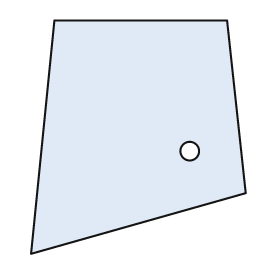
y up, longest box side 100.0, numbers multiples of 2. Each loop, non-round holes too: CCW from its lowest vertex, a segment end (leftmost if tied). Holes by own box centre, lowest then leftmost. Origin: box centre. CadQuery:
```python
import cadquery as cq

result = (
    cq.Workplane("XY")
    .moveTo(-46.0, -50.0)
    .lineTo(46.0, -24.0)
    .lineTo(38.0, 50.0)
    .lineTo(-36.0, 50.0)
    .close()
    .moveTo(22.0, -6.0)
    .circle(4.0)
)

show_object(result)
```